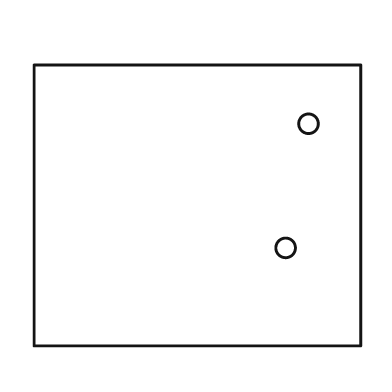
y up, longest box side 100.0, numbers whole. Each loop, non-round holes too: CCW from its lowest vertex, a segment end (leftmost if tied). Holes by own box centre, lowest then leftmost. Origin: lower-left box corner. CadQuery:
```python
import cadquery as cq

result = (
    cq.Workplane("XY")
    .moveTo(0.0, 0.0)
    .lineTo(100.0, 0.0)
    .lineTo(100.0, 86.0)
    .lineTo(0.0, 86.0)
    .close()
    .moveTo(77.0, 30.0)
    .circle(3.0)
    .moveTo(84.0, 68.0)
    .circle(3.0)
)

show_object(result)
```